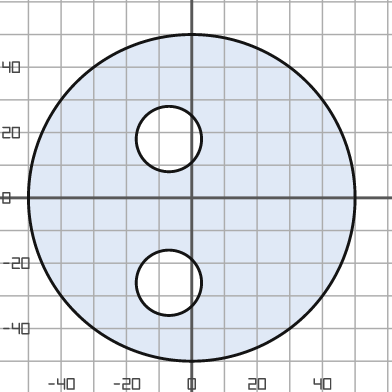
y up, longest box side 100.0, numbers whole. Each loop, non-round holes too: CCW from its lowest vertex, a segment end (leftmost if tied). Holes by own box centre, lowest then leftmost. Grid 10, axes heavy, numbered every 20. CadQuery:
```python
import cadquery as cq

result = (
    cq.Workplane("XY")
    .moveTo(0.0, 0.0)
    .circle(50.0)
    .moveTo(-7.0, -26.0)
    .circle(10.0)
    .moveTo(-7.0, 18.0)
    .circle(10.0)
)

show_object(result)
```